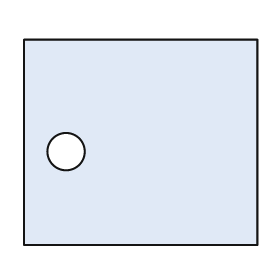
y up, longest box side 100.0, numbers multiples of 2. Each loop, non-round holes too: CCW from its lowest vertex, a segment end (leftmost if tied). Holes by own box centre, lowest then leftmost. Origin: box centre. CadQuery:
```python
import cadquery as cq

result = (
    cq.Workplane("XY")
    .moveTo(-50.0, -44.0)
    .lineTo(50.0, -44.0)
    .lineTo(50.0, 44.0)
    .lineTo(-50.0, 44.0)
    .close()
    .moveTo(-32.0, -4.0)
    .circle(8.0)
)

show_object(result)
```